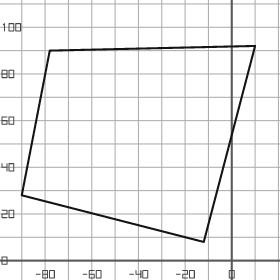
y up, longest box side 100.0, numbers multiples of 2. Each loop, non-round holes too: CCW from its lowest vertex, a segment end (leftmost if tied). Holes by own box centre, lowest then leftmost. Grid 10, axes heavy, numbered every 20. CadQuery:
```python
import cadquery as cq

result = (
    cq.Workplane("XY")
    .moveTo(-12.0, 8.0)
    .lineTo(10.0, 92.0)
    .lineTo(-78.0, 90.0)
    .lineTo(-90.0, 28.0)
    .close()
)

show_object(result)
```